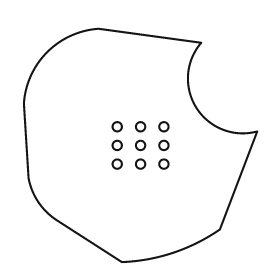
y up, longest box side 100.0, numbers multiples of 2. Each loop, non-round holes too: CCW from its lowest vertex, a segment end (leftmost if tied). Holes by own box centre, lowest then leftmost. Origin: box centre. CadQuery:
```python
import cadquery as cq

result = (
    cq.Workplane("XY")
    .moveTo(-8.0, -50.0)
    .threePointArc((14.0, -46.0), (34.0, -36.0))
    .lineTo(50.0, 6.0)
    .threePointArc((24.0, 16.0), (26.0, 44.0))
    .lineTo(-18.0, 50.0)
    .threePointArc((-40.0, 40.0), (-50.0, 18.0))
    .lineTo(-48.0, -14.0)
    .threePointArc((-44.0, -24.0), (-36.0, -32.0))
    .close()
    .moveTo(-10.0, -8.0)
    .circle(2.0)
    .moveTo(0.0, -8.0)
    .circle(2.0)
    .moveTo(10.0, -8.0)
    .circle(2.0)
    .moveTo(-10.0, 0.0)
    .circle(2.0)
    .moveTo(0.0, 0.0)
    .circle(2.0)
    .moveTo(10.0, 0.0)
    .circle(2.0)
    .moveTo(-10.0, 8.0)
    .circle(2.0)
    .moveTo(0.0, 8.0)
    .circle(2.0)
    .moveTo(10.0, 8.0)
    .circle(2.0)
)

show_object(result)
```